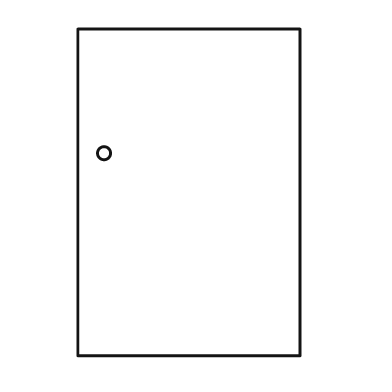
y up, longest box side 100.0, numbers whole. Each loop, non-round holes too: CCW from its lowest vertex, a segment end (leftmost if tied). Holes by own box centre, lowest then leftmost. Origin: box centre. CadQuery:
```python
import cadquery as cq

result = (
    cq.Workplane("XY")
    .moveTo(-34.0, -50.0)
    .lineTo(34.0, -50.0)
    .lineTo(34.0, 50.0)
    .lineTo(-34.0, 50.0)
    .close()
    .moveTo(-26.0, 12.0)
    .circle(2.0)
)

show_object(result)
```